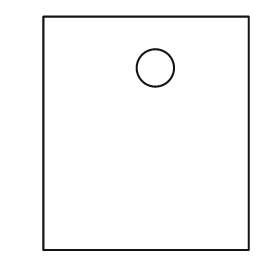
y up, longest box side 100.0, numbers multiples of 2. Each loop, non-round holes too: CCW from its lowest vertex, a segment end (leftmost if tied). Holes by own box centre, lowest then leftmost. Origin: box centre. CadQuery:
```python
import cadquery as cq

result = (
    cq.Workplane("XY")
    .moveTo(-44.0, -50.0)
    .lineTo(44.0, -50.0)
    .lineTo(44.0, 50.0)
    .lineTo(-44.0, 50.0)
    .close()
    .moveTo(4.0, 28.0)
    .circle(8.0)
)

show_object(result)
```